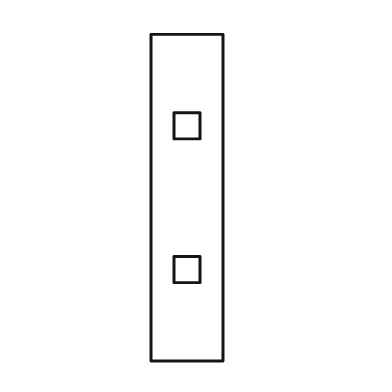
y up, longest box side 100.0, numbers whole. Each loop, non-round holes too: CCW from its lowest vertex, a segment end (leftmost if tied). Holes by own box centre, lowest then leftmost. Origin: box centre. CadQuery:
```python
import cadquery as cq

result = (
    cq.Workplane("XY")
    .moveTo(-11.0, -50.0)
    .lineTo(11.0, -50.0)
    .lineTo(11.0, 50.0)
    .lineTo(-11.0, 50.0)
    .close()
    .moveTo(-4.0, -26.0)
    .lineTo(4.0, -26.0)
    .lineTo(4.0, -18.0)
    .lineTo(-4.0, -18.0)
    .close()
    .moveTo(-4.0, 18.0)
    .lineTo(4.0, 18.0)
    .lineTo(4.0, 26.0)
    .lineTo(-4.0, 26.0)
    .close()
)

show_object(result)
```